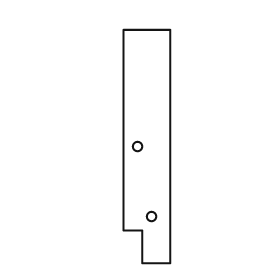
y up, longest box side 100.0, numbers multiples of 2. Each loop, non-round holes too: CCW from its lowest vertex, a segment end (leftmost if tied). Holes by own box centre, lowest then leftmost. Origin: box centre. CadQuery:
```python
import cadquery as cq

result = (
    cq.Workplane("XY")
    .moveTo(-2.0, -50.0)
    .lineTo(10.0, -50.0)
    .lineTo(10.0, 50.0)
    .lineTo(-10.0, 50.0)
    .lineTo(-10.0, -36.0)
    .lineTo(-2.0, -36.0)
    .close()
    .moveTo(2.0, -30.0)
    .circle(2.0)
    .moveTo(-4.0, 0.0)
    .circle(2.0)
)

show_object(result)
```